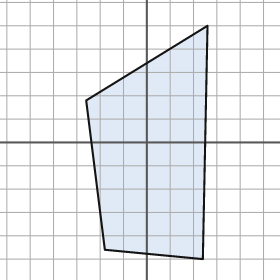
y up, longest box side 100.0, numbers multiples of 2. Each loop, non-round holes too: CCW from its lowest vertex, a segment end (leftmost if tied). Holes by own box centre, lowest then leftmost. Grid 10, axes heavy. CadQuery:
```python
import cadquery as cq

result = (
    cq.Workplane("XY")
    .moveTo(24.0, -50.0)
    .lineTo(26.0, 50.0)
    .lineTo(-26.0, 18.0)
    .lineTo(-18.0, -46.0)
    .close()
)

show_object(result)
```